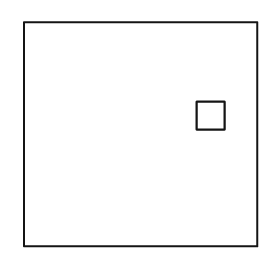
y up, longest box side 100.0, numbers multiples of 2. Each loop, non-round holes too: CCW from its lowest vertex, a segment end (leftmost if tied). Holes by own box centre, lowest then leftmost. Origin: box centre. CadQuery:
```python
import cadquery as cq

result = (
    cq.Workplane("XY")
    .moveTo(-50.0, -48.0)
    .lineTo(50.0, -48.0)
    .lineTo(50.0, 48.0)
    .lineTo(-50.0, 48.0)
    .close()
    .moveTo(24.0, 2.0)
    .lineTo(36.0, 2.0)
    .lineTo(36.0, 14.0)
    .lineTo(24.0, 14.0)
    .close()
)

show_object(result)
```